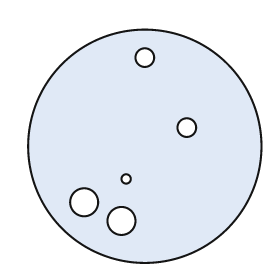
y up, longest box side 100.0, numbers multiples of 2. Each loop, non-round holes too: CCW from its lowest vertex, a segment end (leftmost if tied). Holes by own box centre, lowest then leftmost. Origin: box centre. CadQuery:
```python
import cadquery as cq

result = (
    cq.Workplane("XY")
    .moveTo(0.0, 0.0)
    .circle(50.0)
    .moveTo(-10.0, -32.0)
    .circle(6.0)
    .moveTo(-26.0, -24.0)
    .circle(6.0)
    .moveTo(-8.0, -14.0)
    .circle(2.0)
    .moveTo(18.0, 8.0)
    .circle(4.0)
    .moveTo(0.0, 38.0)
    .circle(4.0)
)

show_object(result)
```